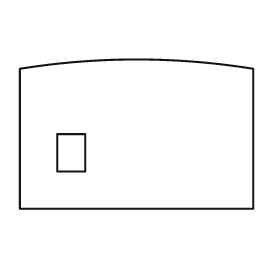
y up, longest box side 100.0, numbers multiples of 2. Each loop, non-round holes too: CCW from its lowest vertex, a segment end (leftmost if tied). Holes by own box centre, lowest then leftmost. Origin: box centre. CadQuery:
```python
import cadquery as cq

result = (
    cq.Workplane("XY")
    .moveTo(-50.0, -32.0)
    .lineTo(50.0, -32.0)
    .lineTo(50.0, 28.0)
    .threePointArc((0.0, 32.0), (-50.0, 28.0))
    .close()
    .moveTo(-34.0, -16.0)
    .lineTo(-22.0, -16.0)
    .lineTo(-22.0, 0.0)
    .lineTo(-34.0, 0.0)
    .close()
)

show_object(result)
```